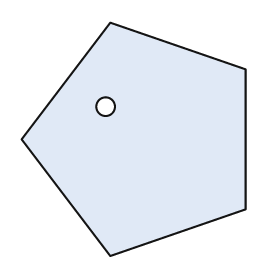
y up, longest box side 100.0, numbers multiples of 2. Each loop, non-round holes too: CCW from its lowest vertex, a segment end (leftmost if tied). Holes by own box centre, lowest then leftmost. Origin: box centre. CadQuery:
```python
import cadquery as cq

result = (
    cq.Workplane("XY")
    .moveTo(-10.0, -50.0)
    .lineTo(48.0, -30.0)
    .lineTo(48.0, 30.0)
    .lineTo(-10.0, 50.0)
    .lineTo(-48.0, 0.0)
    .close()
    .moveTo(-12.0, 14.0)
    .circle(4.0)
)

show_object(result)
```